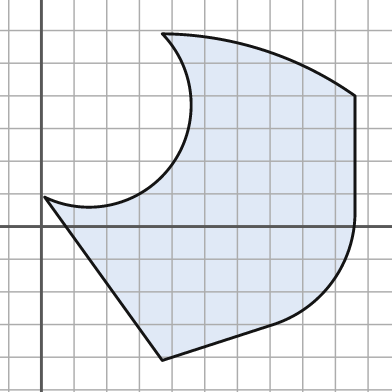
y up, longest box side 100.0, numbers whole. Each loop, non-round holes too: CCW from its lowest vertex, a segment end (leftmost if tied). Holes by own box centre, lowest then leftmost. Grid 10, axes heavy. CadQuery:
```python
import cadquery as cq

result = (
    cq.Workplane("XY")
    .moveTo(37.0, -41.0)
    .lineTo(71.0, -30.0)
    .threePointArc((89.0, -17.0), (96.0, 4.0))
    .lineTo(96.0, 40.0)
    .threePointArc((68.0, 54.0), (37.0, 59.0))
    .threePointArc((40.0, 19.0), (1.0, 9.0))
    .close()
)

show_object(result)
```